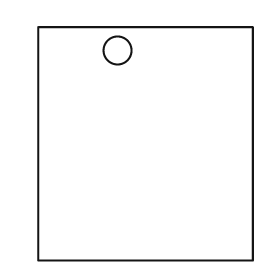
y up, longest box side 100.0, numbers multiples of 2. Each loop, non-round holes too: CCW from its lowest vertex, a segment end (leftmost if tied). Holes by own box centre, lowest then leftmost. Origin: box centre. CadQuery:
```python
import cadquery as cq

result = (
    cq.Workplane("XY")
    .moveTo(-46.0, -50.0)
    .lineTo(46.0, -50.0)
    .lineTo(46.0, 50.0)
    .lineTo(-46.0, 50.0)
    .close()
    .moveTo(-12.0, 40.0)
    .circle(6.0)
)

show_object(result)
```